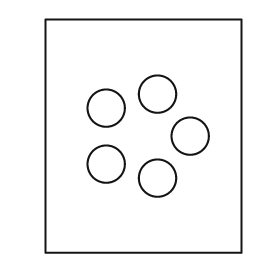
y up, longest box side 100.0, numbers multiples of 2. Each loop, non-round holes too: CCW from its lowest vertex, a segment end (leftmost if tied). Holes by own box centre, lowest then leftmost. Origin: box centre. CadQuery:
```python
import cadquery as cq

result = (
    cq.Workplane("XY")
    .moveTo(-42.0, -50.0)
    .lineTo(42.0, -50.0)
    .lineTo(42.0, 50.0)
    .lineTo(-42.0, 50.0)
    .close()
    .moveTo(6.0, -18.0)
    .circle(8.0)
    .moveTo(-16.0, -12.0)
    .circle(8.0)
    .moveTo(20.0, 0.0)
    .circle(8.0)
    .moveTo(-16.0, 12.0)
    .circle(8.0)
    .moveTo(6.0, 18.0)
    .circle(8.0)
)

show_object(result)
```